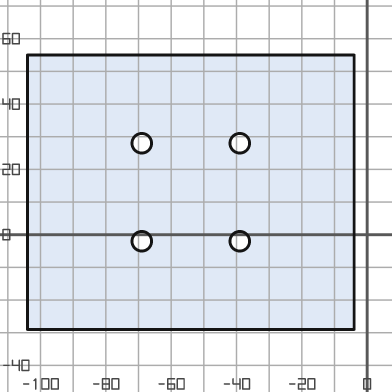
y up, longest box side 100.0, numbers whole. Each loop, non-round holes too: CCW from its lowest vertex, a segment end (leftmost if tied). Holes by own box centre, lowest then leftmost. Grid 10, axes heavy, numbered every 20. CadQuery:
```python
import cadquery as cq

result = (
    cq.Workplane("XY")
    .moveTo(-104.0, -29.0)
    .lineTo(-4.0, -29.0)
    .lineTo(-4.0, 55.0)
    .lineTo(-104.0, 55.0)
    .close()
    .moveTo(-69.0, -2.0)
    .circle(3.0)
    .moveTo(-39.0, -2.0)
    .circle(3.0)
    .moveTo(-69.0, 28.0)
    .circle(3.0)
    .moveTo(-39.0, 28.0)
    .circle(3.0)
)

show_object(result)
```